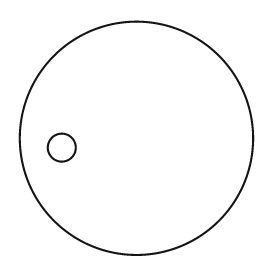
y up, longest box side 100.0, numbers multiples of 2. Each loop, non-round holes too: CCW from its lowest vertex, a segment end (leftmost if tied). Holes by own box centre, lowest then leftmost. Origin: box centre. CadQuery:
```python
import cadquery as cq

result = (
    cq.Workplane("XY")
    .moveTo(0.0, 0.0)
    .circle(50.0)
    .moveTo(-32.0, -4.0)
    .circle(6.0)
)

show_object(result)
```